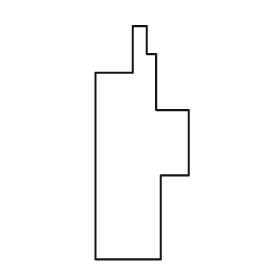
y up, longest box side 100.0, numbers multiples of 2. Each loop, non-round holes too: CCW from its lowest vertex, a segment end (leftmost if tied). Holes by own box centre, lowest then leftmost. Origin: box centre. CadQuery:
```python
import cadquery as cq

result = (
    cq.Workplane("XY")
    .moveTo(-20.0, -50.0)
    .lineTo(8.0, -50.0)
    .lineTo(8.0, -14.0)
    .lineTo(20.0, -14.0)
    .lineTo(20.0, 14.0)
    .lineTo(6.0, 14.0)
    .lineTo(6.0, 38.0)
    .lineTo(2.0, 38.0)
    .lineTo(2.0, 50.0)
    .lineTo(-4.0, 50.0)
    .lineTo(-4.0, 30.0)
    .lineTo(-20.0, 30.0)
    .close()
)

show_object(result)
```